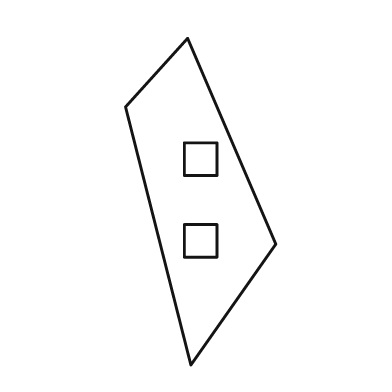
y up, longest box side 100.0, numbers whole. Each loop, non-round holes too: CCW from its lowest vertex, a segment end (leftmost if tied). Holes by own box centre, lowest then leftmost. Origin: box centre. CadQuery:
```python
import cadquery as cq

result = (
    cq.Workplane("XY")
    .moveTo(-3.0, -50.0)
    .lineTo(23.0, -13.0)
    .lineTo(-4.0, 50.0)
    .lineTo(-23.0, 29.0)
    .close()
    .moveTo(-5.0, -17.0)
    .lineTo(5.0, -17.0)
    .lineTo(5.0, -7.0)
    .lineTo(-5.0, -7.0)
    .close()
    .moveTo(-5.0, 8.0)
    .lineTo(5.0, 8.0)
    .lineTo(5.0, 18.0)
    .lineTo(-5.0, 18.0)
    .close()
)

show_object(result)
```